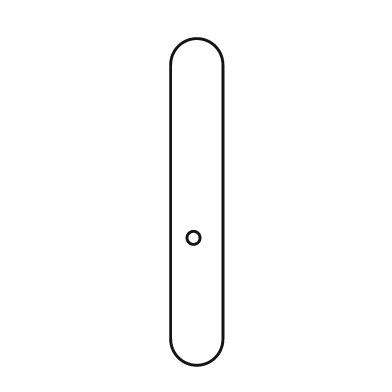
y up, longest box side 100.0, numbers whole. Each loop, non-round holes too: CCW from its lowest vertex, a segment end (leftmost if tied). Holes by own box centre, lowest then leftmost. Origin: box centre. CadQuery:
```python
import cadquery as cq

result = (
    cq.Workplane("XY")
    .moveTo(-8.0, -42.0)
    .threePointArc((0.0, -50.0), (8.0, -42.0))
    .lineTo(8.0, 42.0)
    .threePointArc((0.0, 50.0), (-8.0, 42.0))
    .close()
    .moveTo(-1.0, -11.0)
    .circle(2.0)
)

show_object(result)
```